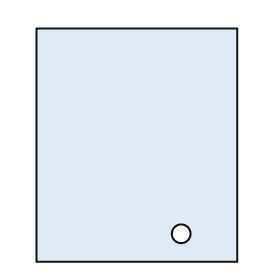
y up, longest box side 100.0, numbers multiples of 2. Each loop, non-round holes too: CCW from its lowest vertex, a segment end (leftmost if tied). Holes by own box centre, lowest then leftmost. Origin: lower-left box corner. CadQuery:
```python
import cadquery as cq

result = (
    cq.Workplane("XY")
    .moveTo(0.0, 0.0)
    .lineTo(86.0, 0.0)
    .lineTo(86.0, 100.0)
    .lineTo(0.0, 100.0)
    .close()
    .moveTo(62.0, 12.0)
    .circle(4.0)
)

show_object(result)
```